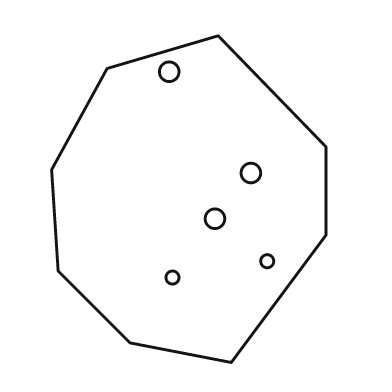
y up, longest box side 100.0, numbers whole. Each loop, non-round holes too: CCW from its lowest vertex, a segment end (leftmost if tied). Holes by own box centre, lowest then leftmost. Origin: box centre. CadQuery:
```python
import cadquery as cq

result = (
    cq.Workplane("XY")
    .moveTo(13.0, -50.0)
    .lineTo(42.0, -11.0)
    .lineTo(42.0, 16.0)
    .lineTo(9.0, 50.0)
    .lineTo(-25.0, 40.0)
    .lineTo(-42.0, 9.0)
    .lineTo(-40.0, -22.0)
    .lineTo(-18.0, -44.0)
    .close()
    .moveTo(-5.0, -24.0)
    .circle(2.0)
    .moveTo(24.0, -19.0)
    .circle(2.0)
    .moveTo(8.0, -6.0)
    .circle(3.0)
    .moveTo(19.0, 8.0)
    .circle(3.0)
    .moveTo(-6.0, 39.0)
    .circle(3.0)
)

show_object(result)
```